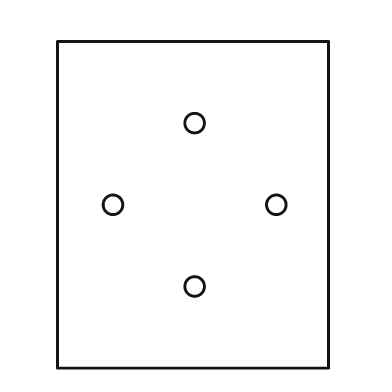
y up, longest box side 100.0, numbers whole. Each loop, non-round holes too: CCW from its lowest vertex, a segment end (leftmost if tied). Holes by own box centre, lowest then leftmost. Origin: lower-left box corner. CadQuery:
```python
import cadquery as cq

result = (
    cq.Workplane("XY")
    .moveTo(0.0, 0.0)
    .lineTo(83.0, 0.0)
    .lineTo(83.0, 100.0)
    .lineTo(0.0, 100.0)
    .close()
    .moveTo(42.0, 25.0)
    .circle(3.0)
    .moveTo(17.0, 50.0)
    .circle(3.0)
    .moveTo(67.0, 50.0)
    .circle(3.0)
    .moveTo(42.0, 75.0)
    .circle(3.0)
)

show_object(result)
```